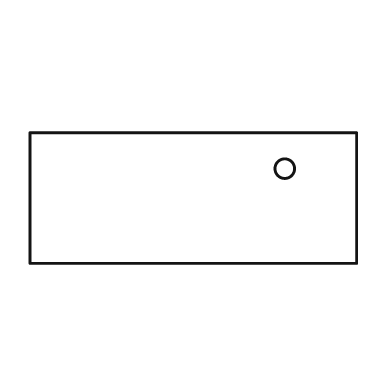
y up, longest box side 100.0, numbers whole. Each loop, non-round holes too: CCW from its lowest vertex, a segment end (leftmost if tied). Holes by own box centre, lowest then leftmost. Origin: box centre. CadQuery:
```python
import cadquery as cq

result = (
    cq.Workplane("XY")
    .moveTo(-50.0, -20.0)
    .lineTo(50.0, -20.0)
    .lineTo(50.0, 20.0)
    .lineTo(-50.0, 20.0)
    .close()
    .moveTo(28.0, 9.0)
    .circle(3.0)
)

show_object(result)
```